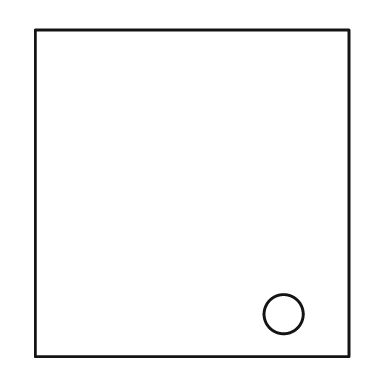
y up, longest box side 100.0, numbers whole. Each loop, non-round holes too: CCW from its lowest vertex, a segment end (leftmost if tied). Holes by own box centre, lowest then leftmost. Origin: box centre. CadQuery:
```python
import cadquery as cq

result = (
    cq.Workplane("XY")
    .moveTo(-48.0, -50.0)
    .lineTo(48.0, -50.0)
    .lineTo(48.0, 50.0)
    .lineTo(-48.0, 50.0)
    .close()
    .moveTo(28.0, -37.0)
    .circle(6.0)
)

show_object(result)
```